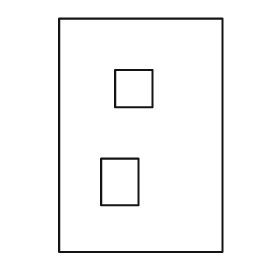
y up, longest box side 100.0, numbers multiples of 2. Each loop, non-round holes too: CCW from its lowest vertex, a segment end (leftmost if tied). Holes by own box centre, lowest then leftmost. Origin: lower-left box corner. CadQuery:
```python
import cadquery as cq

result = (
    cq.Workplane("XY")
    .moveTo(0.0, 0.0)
    .lineTo(70.0, 0.0)
    .lineTo(70.0, 100.0)
    .lineTo(0.0, 100.0)
    .close()
    .moveTo(18.0, 20.0)
    .lineTo(34.0, 20.0)
    .lineTo(34.0, 40.0)
    .lineTo(18.0, 40.0)
    .close()
    .moveTo(24.0, 62.0)
    .lineTo(40.0, 62.0)
    .lineTo(40.0, 78.0)
    .lineTo(24.0, 78.0)
    .close()
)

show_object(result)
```